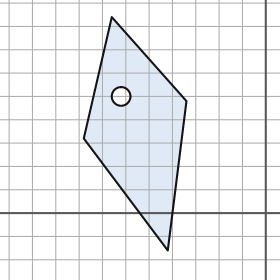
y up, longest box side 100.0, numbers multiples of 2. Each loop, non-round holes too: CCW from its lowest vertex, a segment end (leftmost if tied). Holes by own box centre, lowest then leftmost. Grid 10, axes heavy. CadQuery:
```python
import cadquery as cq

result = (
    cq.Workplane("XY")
    .moveTo(-42.0, -16.0)
    .lineTo(-34.0, 48.0)
    .lineTo(-66.0, 84.0)
    .lineTo(-78.0, 32.0)
    .close()
    .moveTo(-62.0, 50.0)
    .circle(4.0)
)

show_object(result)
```